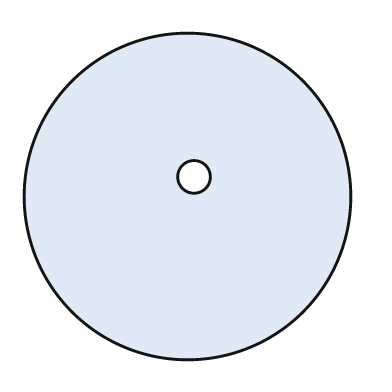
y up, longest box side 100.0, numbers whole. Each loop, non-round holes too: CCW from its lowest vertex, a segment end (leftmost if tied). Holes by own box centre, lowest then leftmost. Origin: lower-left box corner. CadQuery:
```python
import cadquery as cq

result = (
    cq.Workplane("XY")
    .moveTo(50.0, 50.0)
    .circle(50.0)
    .moveTo(52.0, 56.0)
    .circle(5.0)
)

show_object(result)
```